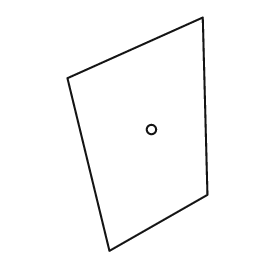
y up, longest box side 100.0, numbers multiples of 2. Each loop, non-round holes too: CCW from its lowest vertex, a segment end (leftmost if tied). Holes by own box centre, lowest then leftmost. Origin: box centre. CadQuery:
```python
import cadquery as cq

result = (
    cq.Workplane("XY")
    .moveTo(-12.0, -50.0)
    .lineTo(30.0, -26.0)
    .lineTo(28.0, 50.0)
    .lineTo(-30.0, 24.0)
    .close()
    .moveTo(6.0, 2.0)
    .circle(2.0)
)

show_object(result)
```